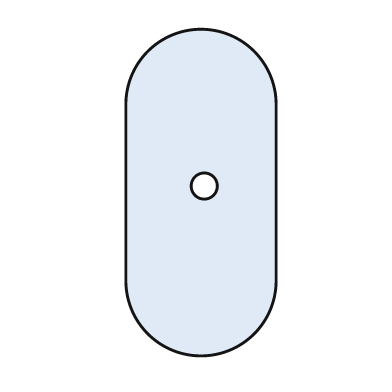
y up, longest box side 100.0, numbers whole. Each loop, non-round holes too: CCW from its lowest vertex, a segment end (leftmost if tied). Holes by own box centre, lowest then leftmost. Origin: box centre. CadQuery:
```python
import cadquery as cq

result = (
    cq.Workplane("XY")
    .moveTo(-23.0, -27.0)
    .threePointArc((0.0, -50.0), (23.0, -27.0))
    .lineTo(23.0, 27.0)
    .threePointArc((0.0, 50.0), (-23.0, 27.0))
    .close()
    .moveTo(1.0, 2.0)
    .circle(4.0)
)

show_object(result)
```